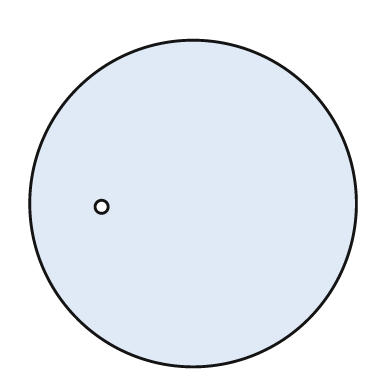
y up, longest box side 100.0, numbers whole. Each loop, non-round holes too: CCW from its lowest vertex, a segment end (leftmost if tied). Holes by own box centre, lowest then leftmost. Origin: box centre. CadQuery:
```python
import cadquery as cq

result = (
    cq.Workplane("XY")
    .moveTo(0.0, 0.0)
    .circle(50.0)
    .moveTo(-28.0, -1.0)
    .circle(2.0)
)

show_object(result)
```